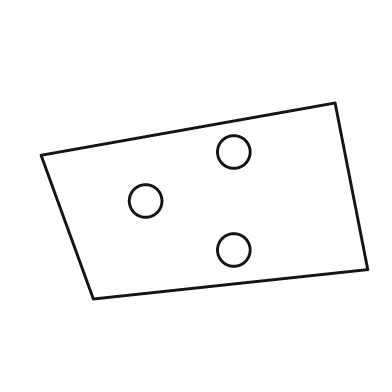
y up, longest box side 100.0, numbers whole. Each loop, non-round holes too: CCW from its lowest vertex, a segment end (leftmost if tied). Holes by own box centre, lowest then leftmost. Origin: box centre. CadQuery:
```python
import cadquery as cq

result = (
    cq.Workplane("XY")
    .moveTo(-34.0, -30.0)
    .lineTo(50.0, -21.0)
    .lineTo(40.0, 30.0)
    .lineTo(-50.0, 14.0)
    .close()
    .moveTo(9.0, -15.0)
    .circle(5.0)
    .moveTo(-18.0, 0.0)
    .circle(5.0)
    .moveTo(9.0, 15.0)
    .circle(5.0)
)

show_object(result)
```